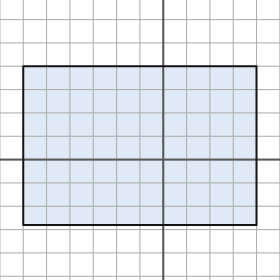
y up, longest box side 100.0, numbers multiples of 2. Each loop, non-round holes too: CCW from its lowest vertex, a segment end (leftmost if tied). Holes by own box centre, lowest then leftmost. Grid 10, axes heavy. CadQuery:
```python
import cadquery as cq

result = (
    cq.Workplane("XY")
    .moveTo(-60.0, -28.0)
    .lineTo(40.0, -28.0)
    .lineTo(40.0, 40.0)
    .lineTo(-60.0, 40.0)
    .close()
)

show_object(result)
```